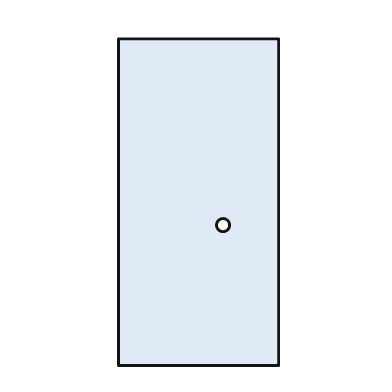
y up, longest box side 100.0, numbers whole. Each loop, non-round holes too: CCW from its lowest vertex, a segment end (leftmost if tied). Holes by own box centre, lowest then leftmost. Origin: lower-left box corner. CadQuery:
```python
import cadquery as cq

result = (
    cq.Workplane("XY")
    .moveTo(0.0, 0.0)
    .lineTo(49.0, 0.0)
    .lineTo(49.0, 100.0)
    .lineTo(0.0, 100.0)
    .close()
    .moveTo(32.0, 43.0)
    .circle(2.0)
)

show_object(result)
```